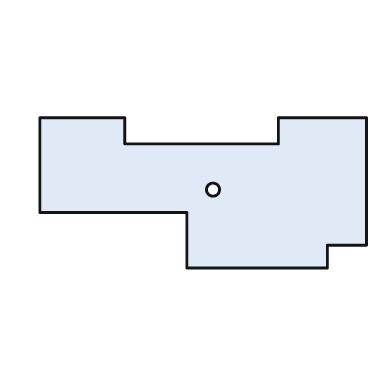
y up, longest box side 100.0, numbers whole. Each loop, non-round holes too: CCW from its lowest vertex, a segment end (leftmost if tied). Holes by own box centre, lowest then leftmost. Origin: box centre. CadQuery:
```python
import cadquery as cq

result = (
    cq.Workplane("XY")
    .moveTo(-5.0, -23.0)
    .lineTo(38.0, -23.0)
    .lineTo(38.0, -16.0)
    .lineTo(50.0, -16.0)
    .lineTo(50.0, 23.0)
    .lineTo(23.0, 23.0)
    .lineTo(23.0, 15.0)
    .lineTo(-24.0, 15.0)
    .lineTo(-24.0, 23.0)
    .lineTo(-50.0, 23.0)
    .lineTo(-50.0, -6.0)
    .lineTo(-5.0, -6.0)
    .close()
    .moveTo(3.0, 1.0)
    .circle(2.0)
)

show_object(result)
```